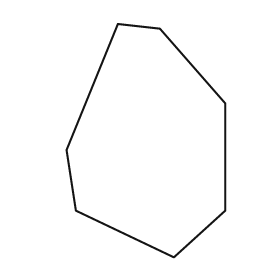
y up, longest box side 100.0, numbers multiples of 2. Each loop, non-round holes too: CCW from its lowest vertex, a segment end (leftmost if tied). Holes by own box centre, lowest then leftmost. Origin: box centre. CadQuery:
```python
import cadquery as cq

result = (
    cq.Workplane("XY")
    .moveTo(12.0, -50.0)
    .lineTo(34.0, -30.0)
    .lineTo(34.0, 16.0)
    .lineTo(6.0, 48.0)
    .lineTo(-12.0, 50.0)
    .lineTo(-34.0, -4.0)
    .lineTo(-30.0, -30.0)
    .close()
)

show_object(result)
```